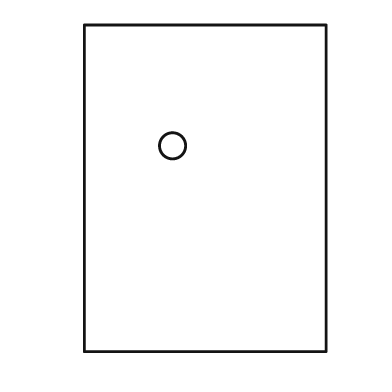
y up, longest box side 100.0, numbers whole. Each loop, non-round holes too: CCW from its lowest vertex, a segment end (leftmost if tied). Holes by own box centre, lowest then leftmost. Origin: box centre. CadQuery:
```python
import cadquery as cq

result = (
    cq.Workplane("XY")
    .moveTo(-37.0, -50.0)
    .lineTo(37.0, -50.0)
    .lineTo(37.0, 50.0)
    .lineTo(-37.0, 50.0)
    .close()
    .moveTo(-10.0, 13.0)
    .circle(4.0)
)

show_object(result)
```